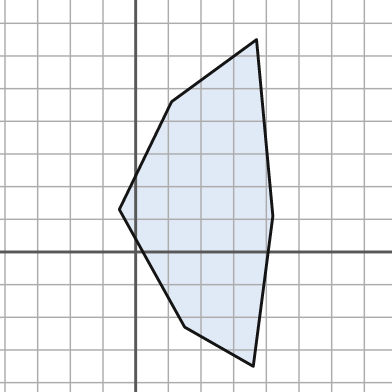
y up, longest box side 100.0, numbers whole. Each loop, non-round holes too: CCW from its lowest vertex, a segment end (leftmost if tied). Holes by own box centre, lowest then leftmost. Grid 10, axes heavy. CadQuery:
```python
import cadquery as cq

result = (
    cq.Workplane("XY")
    .moveTo(36.0, -35.0)
    .lineTo(42.0, 11.0)
    .lineTo(37.0, 65.0)
    .lineTo(11.0, 46.0)
    .lineTo(-5.0, 13.0)
    .lineTo(15.0, -23.0)
    .close()
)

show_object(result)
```